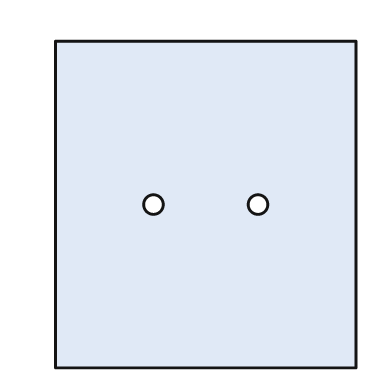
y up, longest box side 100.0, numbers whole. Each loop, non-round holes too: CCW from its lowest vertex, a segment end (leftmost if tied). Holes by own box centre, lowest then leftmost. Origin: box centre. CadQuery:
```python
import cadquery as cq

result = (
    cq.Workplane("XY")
    .moveTo(-46.0, -50.0)
    .lineTo(46.0, -50.0)
    .lineTo(46.0, 50.0)
    .lineTo(-46.0, 50.0)
    .close()
    .moveTo(-16.0, 0.0)
    .circle(3.0)
    .moveTo(16.0, 0.0)
    .circle(3.0)
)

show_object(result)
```